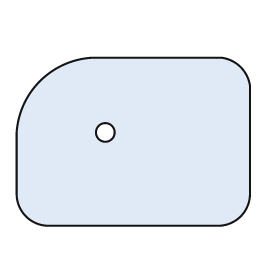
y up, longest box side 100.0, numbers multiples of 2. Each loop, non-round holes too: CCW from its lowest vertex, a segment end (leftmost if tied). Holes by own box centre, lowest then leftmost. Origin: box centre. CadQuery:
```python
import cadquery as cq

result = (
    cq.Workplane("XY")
    .moveTo(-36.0, -36.0)
    .lineTo(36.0, -36.0)
    .threePointArc((46.0, -32.0), (50.0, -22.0))
    .lineTo(50.0, 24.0)
    .threePointArc((46.0, 32.0), (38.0, 36.0))
    .lineTo(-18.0, 36.0)
    .threePointArc((-40.0, 26.0), (-50.0, 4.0))
    .lineTo(-50.0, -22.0)
    .threePointArc((-46.0, -32.0), (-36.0, -36.0))
    .close()
    .moveTo(-12.0, 4.0)
    .circle(4.0)
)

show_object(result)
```